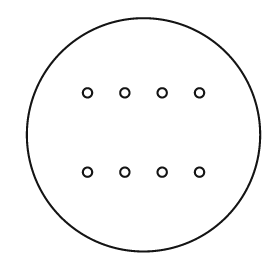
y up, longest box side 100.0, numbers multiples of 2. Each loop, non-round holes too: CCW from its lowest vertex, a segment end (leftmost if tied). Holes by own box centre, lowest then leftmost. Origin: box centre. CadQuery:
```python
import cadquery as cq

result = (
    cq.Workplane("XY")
    .moveTo(0.0, 0.0)
    .circle(50.0)
    .moveTo(-24.0, -16.0)
    .circle(2.0)
    .moveTo(-8.0, -16.0)
    .circle(2.0)
    .moveTo(8.0, -16.0)
    .circle(2.0)
    .moveTo(24.0, -16.0)
    .circle(2.0)
    .moveTo(-24.0, 18.0)
    .circle(2.0)
    .moveTo(-8.0, 18.0)
    .circle(2.0)
    .moveTo(8.0, 18.0)
    .circle(2.0)
    .moveTo(24.0, 18.0)
    .circle(2.0)
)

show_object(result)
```